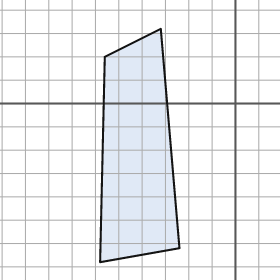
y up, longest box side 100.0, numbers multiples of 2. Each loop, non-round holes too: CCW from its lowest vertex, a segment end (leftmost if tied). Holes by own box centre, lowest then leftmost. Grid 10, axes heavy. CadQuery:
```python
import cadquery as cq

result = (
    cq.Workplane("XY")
    .moveTo(-58.0, -68.0)
    .lineTo(-24.0, -62.0)
    .lineTo(-32.0, 32.0)
    .lineTo(-56.0, 20.0)
    .close()
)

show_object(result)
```